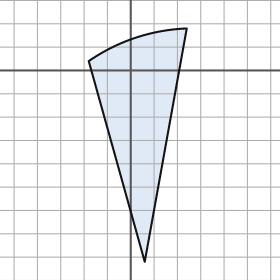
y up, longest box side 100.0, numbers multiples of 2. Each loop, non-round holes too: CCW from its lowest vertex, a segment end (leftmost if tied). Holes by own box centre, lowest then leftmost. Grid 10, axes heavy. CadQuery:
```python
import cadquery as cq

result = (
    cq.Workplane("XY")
    .moveTo(6.0, -82.0)
    .lineTo(24.0, 18.0)
    .threePointArc((2.0, 14.0), (-18.0, 4.0))
    .close()
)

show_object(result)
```